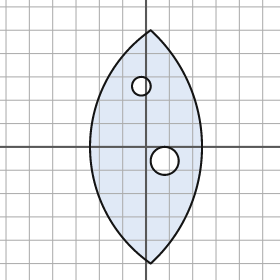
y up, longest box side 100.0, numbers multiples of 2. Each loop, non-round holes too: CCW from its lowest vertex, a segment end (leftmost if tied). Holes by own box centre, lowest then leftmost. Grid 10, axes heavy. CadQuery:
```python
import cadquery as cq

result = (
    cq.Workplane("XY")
    .moveTo(2.0, -50.0)
    .threePointArc((24.0, 0.0), (2.0, 50.0))
    .threePointArc((-24.0, 0.0), (2.0, -50.0))
    .close()
    .moveTo(8.0, -6.0)
    .circle(6.0)
    .moveTo(-2.0, 26.0)
    .circle(4.0)
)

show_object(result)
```